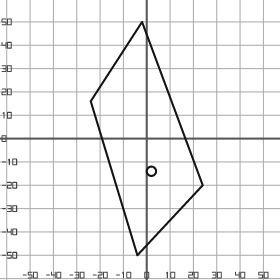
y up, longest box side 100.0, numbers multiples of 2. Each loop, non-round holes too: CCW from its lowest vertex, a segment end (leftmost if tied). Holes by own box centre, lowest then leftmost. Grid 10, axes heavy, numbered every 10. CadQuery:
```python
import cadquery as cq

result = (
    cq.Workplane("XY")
    .moveTo(-4.0, -50.0)
    .lineTo(24.0, -20.0)
    .lineTo(-2.0, 50.0)
    .lineTo(-24.0, 16.0)
    .close()
    .moveTo(2.0, -14.0)
    .circle(2.0)
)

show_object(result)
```